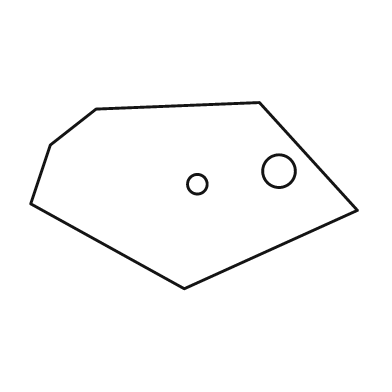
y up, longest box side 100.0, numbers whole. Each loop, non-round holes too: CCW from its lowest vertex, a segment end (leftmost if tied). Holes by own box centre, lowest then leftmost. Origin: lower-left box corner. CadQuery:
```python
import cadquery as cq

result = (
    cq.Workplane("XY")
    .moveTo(47.0, 0.0)
    .lineTo(100.0, 24.0)
    .lineTo(70.0, 57.0)
    .lineTo(20.0, 55.0)
    .lineTo(6.0, 44.0)
    .lineTo(0.0, 26.0)
    .close()
    .moveTo(51.0, 32.0)
    .circle(3.0)
    .moveTo(76.0, 36.0)
    .circle(5.0)
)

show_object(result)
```